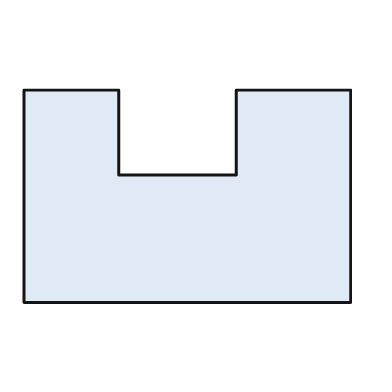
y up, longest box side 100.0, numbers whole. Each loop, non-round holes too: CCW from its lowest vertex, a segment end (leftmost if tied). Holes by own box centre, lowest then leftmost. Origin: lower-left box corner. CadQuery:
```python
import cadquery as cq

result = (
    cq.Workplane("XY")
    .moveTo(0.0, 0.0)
    .lineTo(100.0, 0.0)
    .lineTo(100.0, 65.0)
    .lineTo(65.0, 65.0)
    .lineTo(65.0, 39.0)
    .lineTo(29.0, 39.0)
    .lineTo(29.0, 65.0)
    .lineTo(0.0, 65.0)
    .close()
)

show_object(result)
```